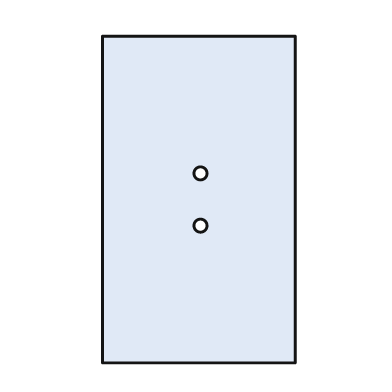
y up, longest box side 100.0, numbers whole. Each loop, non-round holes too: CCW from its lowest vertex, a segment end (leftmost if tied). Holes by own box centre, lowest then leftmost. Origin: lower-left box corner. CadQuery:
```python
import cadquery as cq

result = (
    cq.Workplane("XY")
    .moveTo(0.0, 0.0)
    .lineTo(59.0, 0.0)
    .lineTo(59.0, 100.0)
    .lineTo(0.0, 100.0)
    .close()
    .moveTo(30.0, 42.0)
    .circle(2.0)
    .moveTo(30.0, 58.0)
    .circle(2.0)
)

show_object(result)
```